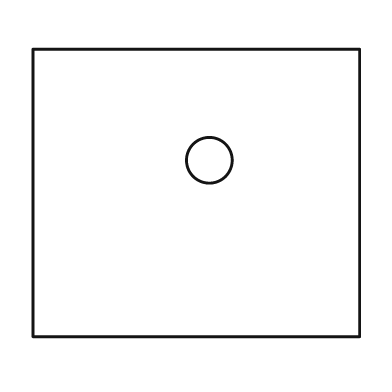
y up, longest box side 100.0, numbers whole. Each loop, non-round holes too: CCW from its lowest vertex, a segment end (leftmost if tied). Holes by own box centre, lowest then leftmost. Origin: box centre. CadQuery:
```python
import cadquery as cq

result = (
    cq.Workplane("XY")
    .moveTo(-50.0, -44.0)
    .lineTo(50.0, -44.0)
    .lineTo(50.0, 44.0)
    .lineTo(-50.0, 44.0)
    .close()
    .moveTo(4.0, 10.0)
    .circle(7.0)
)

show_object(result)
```